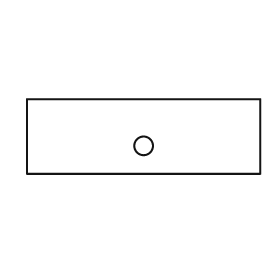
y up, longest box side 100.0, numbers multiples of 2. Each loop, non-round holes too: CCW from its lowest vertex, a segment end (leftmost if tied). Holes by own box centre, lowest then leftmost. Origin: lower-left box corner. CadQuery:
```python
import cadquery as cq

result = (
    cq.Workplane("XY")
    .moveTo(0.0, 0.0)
    .lineTo(100.0, 0.0)
    .lineTo(100.0, 32.0)
    .lineTo(0.0, 32.0)
    .close()
    .moveTo(50.0, 12.0)
    .circle(4.0)
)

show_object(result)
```